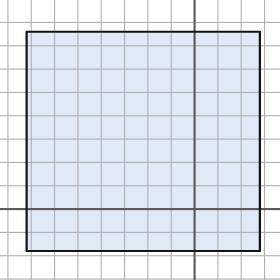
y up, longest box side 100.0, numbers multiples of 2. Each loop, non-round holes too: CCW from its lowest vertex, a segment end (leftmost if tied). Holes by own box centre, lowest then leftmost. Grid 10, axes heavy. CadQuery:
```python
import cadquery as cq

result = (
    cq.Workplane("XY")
    .moveTo(-72.0, -18.0)
    .lineTo(28.0, -18.0)
    .lineTo(28.0, 76.0)
    .lineTo(-72.0, 76.0)
    .close()
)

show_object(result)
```